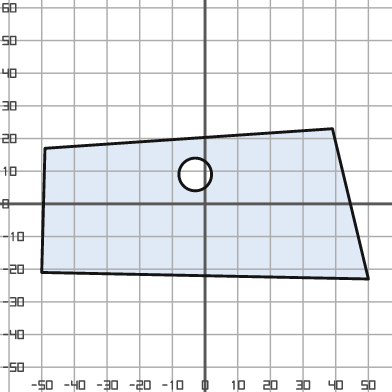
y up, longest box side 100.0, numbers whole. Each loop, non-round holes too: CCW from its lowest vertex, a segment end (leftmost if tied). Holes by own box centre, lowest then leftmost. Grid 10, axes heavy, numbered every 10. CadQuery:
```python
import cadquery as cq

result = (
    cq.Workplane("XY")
    .moveTo(50.0, -23.0)
    .lineTo(39.0, 23.0)
    .lineTo(-49.0, 17.0)
    .lineTo(-50.0, -21.0)
    .close()
    .moveTo(-3.0, 9.0)
    .circle(5.0)
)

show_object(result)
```